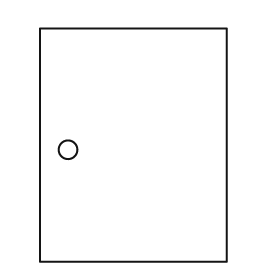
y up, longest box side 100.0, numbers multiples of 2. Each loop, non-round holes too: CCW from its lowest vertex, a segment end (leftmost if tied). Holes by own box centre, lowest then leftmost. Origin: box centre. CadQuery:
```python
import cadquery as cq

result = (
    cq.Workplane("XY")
    .moveTo(-40.0, -50.0)
    .lineTo(40.0, -50.0)
    .lineTo(40.0, 50.0)
    .lineTo(-40.0, 50.0)
    .close()
    .moveTo(-28.0, -2.0)
    .circle(4.0)
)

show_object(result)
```